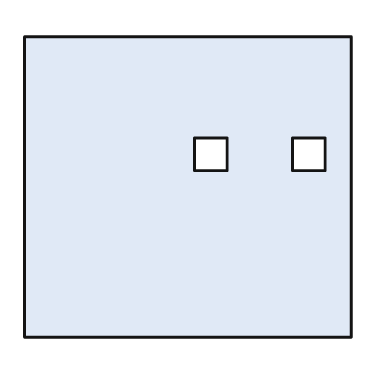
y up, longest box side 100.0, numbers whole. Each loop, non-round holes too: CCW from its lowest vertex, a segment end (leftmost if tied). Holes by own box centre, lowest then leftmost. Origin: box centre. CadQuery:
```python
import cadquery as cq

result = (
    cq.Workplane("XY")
    .moveTo(-50.0, -46.0)
    .lineTo(50.0, -46.0)
    .lineTo(50.0, 46.0)
    .lineTo(-50.0, 46.0)
    .close()
    .moveTo(2.0, 5.0)
    .lineTo(12.0, 5.0)
    .lineTo(12.0, 15.0)
    .lineTo(2.0, 15.0)
    .close()
    .moveTo(32.0, 5.0)
    .lineTo(42.0, 5.0)
    .lineTo(42.0, 15.0)
    .lineTo(32.0, 15.0)
    .close()
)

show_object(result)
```